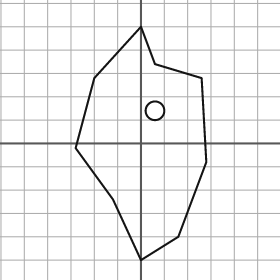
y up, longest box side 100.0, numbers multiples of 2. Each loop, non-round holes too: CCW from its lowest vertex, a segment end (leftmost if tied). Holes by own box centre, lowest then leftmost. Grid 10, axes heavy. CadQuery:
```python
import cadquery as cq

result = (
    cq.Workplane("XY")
    .moveTo(0.0, -50.0)
    .lineTo(16.0, -40.0)
    .lineTo(28.0, -8.0)
    .lineTo(26.0, 28.0)
    .lineTo(6.0, 34.0)
    .lineTo(0.0, 50.0)
    .lineTo(-20.0, 28.0)
    .lineTo(-28.0, -2.0)
    .lineTo(-12.0, -24.0)
    .close()
    .moveTo(6.0, 14.0)
    .circle(4.0)
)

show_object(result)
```